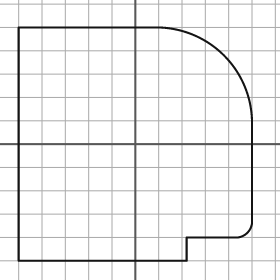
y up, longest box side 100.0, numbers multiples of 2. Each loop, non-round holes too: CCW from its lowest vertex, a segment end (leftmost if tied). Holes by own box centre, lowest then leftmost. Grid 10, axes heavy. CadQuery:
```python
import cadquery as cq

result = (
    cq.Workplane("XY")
    .moveTo(-50.0, -50.0)
    .lineTo(22.0, -50.0)
    .lineTo(22.0, -40.0)
    .lineTo(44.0, -40.0)
    .threePointArc((48.0, -38.0), (50.0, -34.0))
    .lineTo(50.0, 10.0)
    .threePointArc((38.0, 38.0), (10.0, 50.0))
    .lineTo(-50.0, 50.0)
    .close()
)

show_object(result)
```